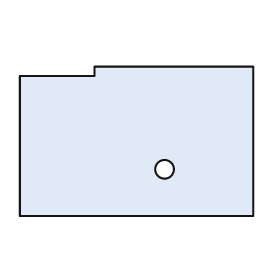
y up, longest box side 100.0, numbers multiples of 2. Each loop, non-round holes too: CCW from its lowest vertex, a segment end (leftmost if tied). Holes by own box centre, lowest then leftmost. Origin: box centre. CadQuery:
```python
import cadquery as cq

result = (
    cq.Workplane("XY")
    .moveTo(-50.0, -32.0)
    .lineTo(50.0, -32.0)
    .lineTo(50.0, 32.0)
    .lineTo(-18.0, 32.0)
    .lineTo(-18.0, 28.0)
    .lineTo(-50.0, 28.0)
    .close()
    .moveTo(12.0, -12.0)
    .circle(4.0)
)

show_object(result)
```